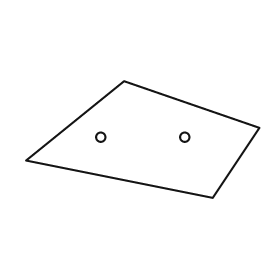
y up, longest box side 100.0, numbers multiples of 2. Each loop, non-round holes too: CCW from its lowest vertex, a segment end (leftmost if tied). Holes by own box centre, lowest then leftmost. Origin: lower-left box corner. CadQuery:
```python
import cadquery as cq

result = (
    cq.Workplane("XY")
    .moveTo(80.0, 0.0)
    .lineTo(100.0, 30.0)
    .lineTo(42.0, 50.0)
    .lineTo(0.0, 16.0)
    .close()
    .moveTo(32.0, 26.0)
    .circle(2.0)
    .moveTo(68.0, 26.0)
    .circle(2.0)
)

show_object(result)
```